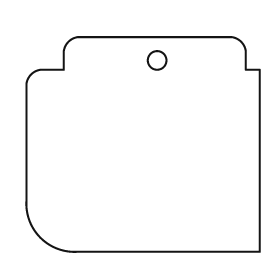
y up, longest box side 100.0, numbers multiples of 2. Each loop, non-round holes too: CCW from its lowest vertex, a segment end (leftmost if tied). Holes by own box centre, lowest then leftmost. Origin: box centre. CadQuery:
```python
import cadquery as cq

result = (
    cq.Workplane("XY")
    .moveTo(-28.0, -46.0)
    .lineTo(50.0, -46.0)
    .lineTo(50.0, 32.0)
    .lineTo(44.0, 32.0)
    .lineTo(44.0, 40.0)
    .threePointArc((42.0, 44.0), (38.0, 46.0))
    .lineTo(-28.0, 46.0)
    .threePointArc((-32.0, 44.0), (-34.0, 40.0))
    .lineTo(-34.0, 32.0)
    .lineTo(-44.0, 32.0)
    .threePointArc((-48.0, 30.0), (-50.0, 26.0))
    .lineTo(-50.0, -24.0)
    .threePointArc((-44.0, -40.0), (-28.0, -46.0))
    .close()
    .moveTo(6.0, 36.0)
    .circle(4.0)
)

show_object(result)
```